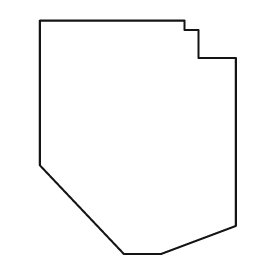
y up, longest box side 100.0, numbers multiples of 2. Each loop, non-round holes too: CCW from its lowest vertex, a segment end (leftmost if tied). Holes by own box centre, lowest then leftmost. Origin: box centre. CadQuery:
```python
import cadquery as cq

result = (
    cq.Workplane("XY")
    .moveTo(-6.0, -50.0)
    .lineTo(10.0, -50.0)
    .lineTo(42.0, -38.0)
    .lineTo(42.0, 34.0)
    .lineTo(26.0, 34.0)
    .lineTo(26.0, 46.0)
    .lineTo(20.0, 46.0)
    .lineTo(20.0, 50.0)
    .lineTo(-42.0, 50.0)
    .lineTo(-42.0, -12.0)
    .close()
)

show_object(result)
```